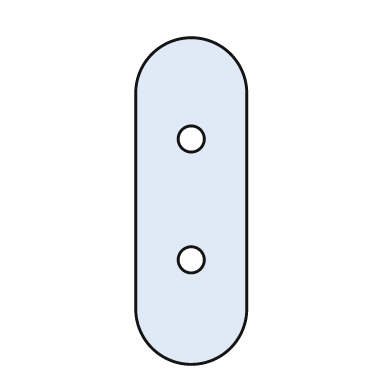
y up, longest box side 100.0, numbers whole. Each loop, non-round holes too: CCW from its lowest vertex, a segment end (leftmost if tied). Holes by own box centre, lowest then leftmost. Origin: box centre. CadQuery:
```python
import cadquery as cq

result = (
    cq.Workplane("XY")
    .moveTo(-17.0, -33.0)
    .threePointArc((0.0, -50.0), (17.0, -33.0))
    .lineTo(17.0, 33.0)
    .threePointArc((0.0, 50.0), (-17.0, 33.0))
    .close()
    .moveTo(0.0, -18.0)
    .circle(4.0)
    .moveTo(0.0, 19.0)
    .circle(4.0)
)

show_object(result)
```